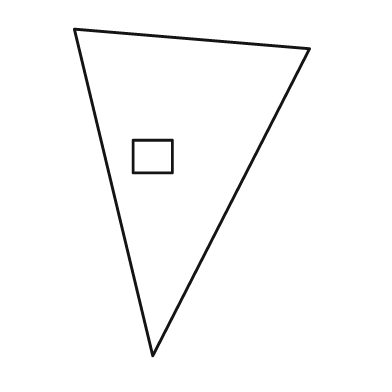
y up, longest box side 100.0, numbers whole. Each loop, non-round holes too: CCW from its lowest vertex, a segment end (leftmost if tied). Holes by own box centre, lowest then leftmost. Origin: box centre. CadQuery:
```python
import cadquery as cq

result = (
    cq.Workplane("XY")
    .moveTo(-12.0, -50.0)
    .lineTo(36.0, 44.0)
    .lineTo(-36.0, 50.0)
    .close()
    .moveTo(-18.0, 6.0)
    .lineTo(-6.0, 6.0)
    .lineTo(-6.0, 16.0)
    .lineTo(-18.0, 16.0)
    .close()
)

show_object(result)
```